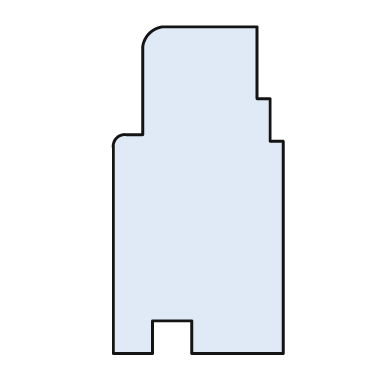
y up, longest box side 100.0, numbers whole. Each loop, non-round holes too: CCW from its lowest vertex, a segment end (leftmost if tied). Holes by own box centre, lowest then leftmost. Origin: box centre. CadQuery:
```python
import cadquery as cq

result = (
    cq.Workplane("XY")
    .moveTo(-26.0, -50.0)
    .lineTo(-14.0, -50.0)
    .lineTo(-14.0, -40.0)
    .lineTo(-2.0, -40.0)
    .lineTo(-2.0, -50.0)
    .lineTo(26.0, -50.0)
    .lineTo(26.0, 15.0)
    .lineTo(22.0, 15.0)
    .lineTo(22.0, 28.0)
    .lineTo(18.0, 28.0)
    .lineTo(18.0, 50.0)
    .lineTo(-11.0, 50.0)
    .threePointArc((-15.0, 48.0), (-17.0, 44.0))
    .lineTo(-17.0, 17.0)
    .lineTo(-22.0, 17.0)
    .threePointArc((-25.0, 16.0), (-26.0, 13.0))
    .close()
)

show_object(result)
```